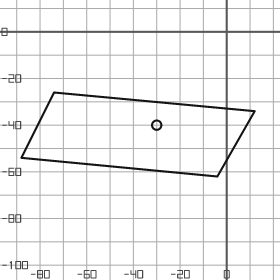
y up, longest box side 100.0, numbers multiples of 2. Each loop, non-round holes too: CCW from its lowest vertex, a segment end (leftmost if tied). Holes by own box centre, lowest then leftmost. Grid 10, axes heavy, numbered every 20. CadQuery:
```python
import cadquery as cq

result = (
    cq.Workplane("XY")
    .moveTo(-4.0, -62.0)
    .lineTo(12.0, -34.0)
    .lineTo(-74.0, -26.0)
    .lineTo(-88.0, -54.0)
    .close()
    .moveTo(-30.0, -40.0)
    .circle(2.0)
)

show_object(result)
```